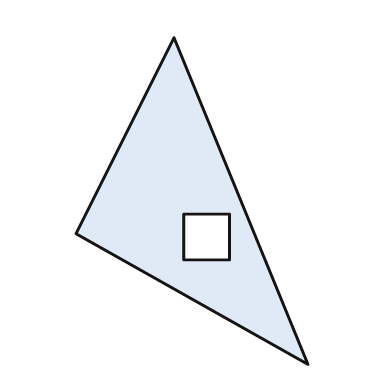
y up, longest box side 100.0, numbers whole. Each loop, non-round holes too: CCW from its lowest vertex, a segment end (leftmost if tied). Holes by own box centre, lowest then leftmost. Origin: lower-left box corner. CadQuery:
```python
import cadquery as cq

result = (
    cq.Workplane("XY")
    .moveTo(71.0, 0.0)
    .lineTo(30.0, 100.0)
    .lineTo(0.0, 40.0)
    .close()
    .moveTo(33.0, 32.0)
    .lineTo(47.0, 32.0)
    .lineTo(47.0, 46.0)
    .lineTo(33.0, 46.0)
    .close()
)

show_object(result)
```